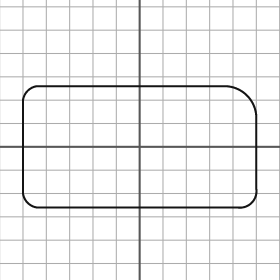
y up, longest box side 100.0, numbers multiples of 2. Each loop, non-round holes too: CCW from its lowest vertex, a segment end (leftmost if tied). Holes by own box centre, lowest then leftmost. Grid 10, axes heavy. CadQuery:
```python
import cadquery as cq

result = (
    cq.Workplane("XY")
    .moveTo(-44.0, -26.0)
    .lineTo(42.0, -26.0)
    .threePointArc((48.0, -24.0), (50.0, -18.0))
    .lineTo(50.0, 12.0)
    .threePointArc((46.0, 22.0), (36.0, 26.0))
    .lineTo(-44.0, 26.0)
    .threePointArc((-48.0, 24.0), (-50.0, 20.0))
    .lineTo(-50.0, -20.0)
    .threePointArc((-48.0, -24.0), (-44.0, -26.0))
    .close()
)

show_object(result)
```